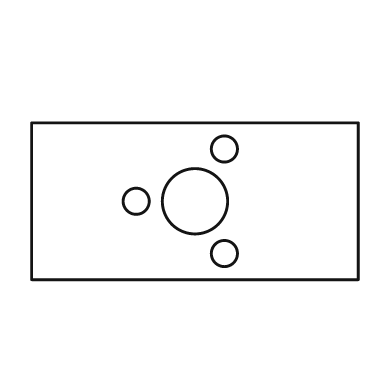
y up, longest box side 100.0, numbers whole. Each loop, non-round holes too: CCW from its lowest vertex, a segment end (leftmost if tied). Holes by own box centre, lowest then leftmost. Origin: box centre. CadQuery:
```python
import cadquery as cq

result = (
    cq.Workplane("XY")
    .moveTo(-50.0, -24.0)
    .lineTo(50.0, -24.0)
    .lineTo(50.0, 24.0)
    .lineTo(-50.0, 24.0)
    .close()
    .moveTo(9.0, -16.0)
    .circle(4.0)
    .moveTo(-18.0, 0.0)
    .circle(4.0)
    .moveTo(0.0, 0.0)
    .circle(10.0)
    .moveTo(9.0, 16.0)
    .circle(4.0)
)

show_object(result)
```